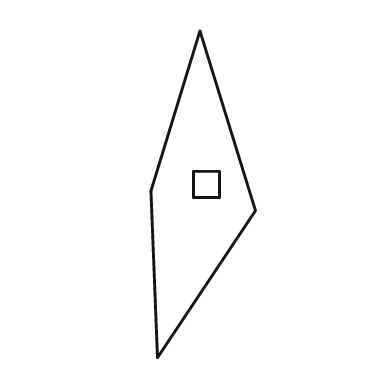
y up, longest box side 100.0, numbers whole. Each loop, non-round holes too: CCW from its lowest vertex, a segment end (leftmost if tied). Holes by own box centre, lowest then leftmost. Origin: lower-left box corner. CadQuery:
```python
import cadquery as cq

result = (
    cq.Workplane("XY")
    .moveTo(2.0, 0.0)
    .lineTo(32.0, 45.0)
    .lineTo(15.0, 100.0)
    .lineTo(0.0, 51.0)
    .close()
    .moveTo(13.0, 49.0)
    .lineTo(21.0, 49.0)
    .lineTo(21.0, 57.0)
    .lineTo(13.0, 57.0)
    .close()
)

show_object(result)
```